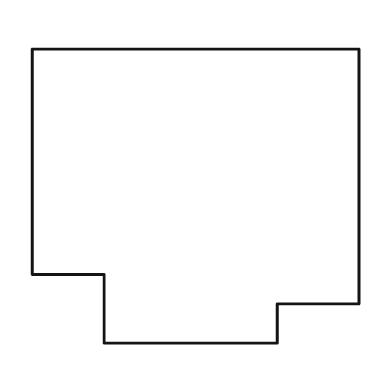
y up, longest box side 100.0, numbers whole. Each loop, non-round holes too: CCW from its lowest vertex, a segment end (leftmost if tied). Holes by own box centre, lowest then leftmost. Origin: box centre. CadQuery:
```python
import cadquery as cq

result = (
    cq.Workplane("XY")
    .moveTo(-28.0, -45.0)
    .lineTo(25.0, -45.0)
    .lineTo(25.0, -33.0)
    .lineTo(50.0, -33.0)
    .lineTo(50.0, 45.0)
    .lineTo(-50.0, 45.0)
    .lineTo(-50.0, -24.0)
    .lineTo(-28.0, -24.0)
    .close()
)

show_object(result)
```